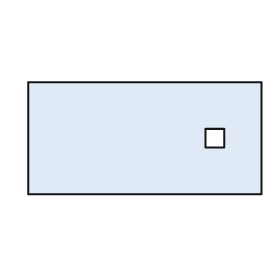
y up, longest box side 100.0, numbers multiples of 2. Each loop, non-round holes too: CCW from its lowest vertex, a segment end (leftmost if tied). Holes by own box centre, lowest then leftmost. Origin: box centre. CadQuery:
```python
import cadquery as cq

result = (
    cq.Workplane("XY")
    .moveTo(-50.0, -24.0)
    .lineTo(50.0, -24.0)
    .lineTo(50.0, 24.0)
    .lineTo(-50.0, 24.0)
    .close()
    .moveTo(26.0, -4.0)
    .lineTo(34.0, -4.0)
    .lineTo(34.0, 4.0)
    .lineTo(26.0, 4.0)
    .close()
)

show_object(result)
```